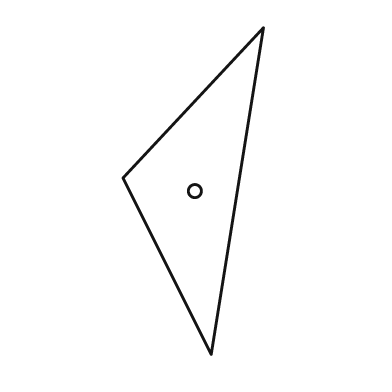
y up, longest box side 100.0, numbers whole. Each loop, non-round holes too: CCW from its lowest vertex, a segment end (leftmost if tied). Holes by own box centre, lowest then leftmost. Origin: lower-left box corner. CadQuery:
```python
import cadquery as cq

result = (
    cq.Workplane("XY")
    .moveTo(27.0, 0.0)
    .lineTo(43.0, 100.0)
    .lineTo(0.0, 54.0)
    .close()
    .moveTo(22.0, 50.0)
    .circle(2.0)
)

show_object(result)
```